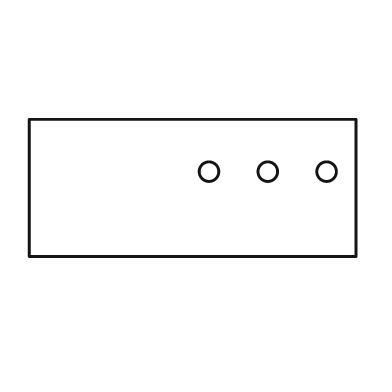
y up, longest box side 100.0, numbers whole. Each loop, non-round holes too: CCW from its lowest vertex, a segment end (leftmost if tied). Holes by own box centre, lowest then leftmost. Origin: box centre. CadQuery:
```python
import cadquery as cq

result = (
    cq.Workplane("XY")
    .moveTo(-50.0, -21.0)
    .lineTo(50.0, -21.0)
    .lineTo(50.0, 21.0)
    .lineTo(-50.0, 21.0)
    .close()
    .moveTo(5.0, 5.0)
    .circle(3.0)
    .moveTo(23.0, 5.0)
    .circle(3.0)
    .moveTo(41.0, 5.0)
    .circle(3.0)
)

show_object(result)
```